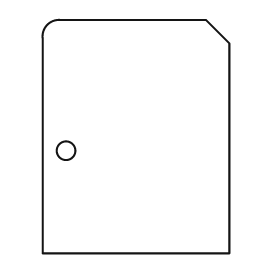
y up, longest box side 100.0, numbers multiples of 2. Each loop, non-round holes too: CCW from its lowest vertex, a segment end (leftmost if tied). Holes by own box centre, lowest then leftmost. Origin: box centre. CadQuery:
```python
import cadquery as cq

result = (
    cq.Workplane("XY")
    .moveTo(-40.0, -50.0)
    .lineTo(40.0, -50.0)
    .lineTo(40.0, 40.0)
    .lineTo(30.0, 50.0)
    .lineTo(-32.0, 50.0)
    .threePointArc((-38.0, 48.0), (-40.0, 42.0))
    .close()
    .moveTo(-30.0, -6.0)
    .circle(4.0)
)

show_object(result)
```